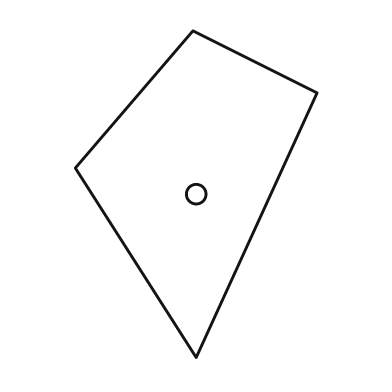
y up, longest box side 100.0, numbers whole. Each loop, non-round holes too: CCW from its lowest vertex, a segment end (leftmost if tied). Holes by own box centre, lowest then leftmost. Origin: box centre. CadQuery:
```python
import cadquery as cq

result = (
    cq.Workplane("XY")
    .moveTo(0.0, -50.0)
    .lineTo(37.0, 31.0)
    .lineTo(-1.0, 50.0)
    .lineTo(-37.0, 8.0)
    .close()
    .moveTo(0.0, 0.0)
    .circle(3.0)
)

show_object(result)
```